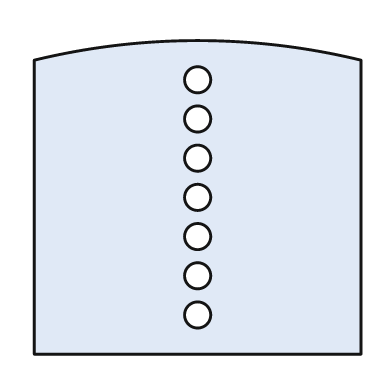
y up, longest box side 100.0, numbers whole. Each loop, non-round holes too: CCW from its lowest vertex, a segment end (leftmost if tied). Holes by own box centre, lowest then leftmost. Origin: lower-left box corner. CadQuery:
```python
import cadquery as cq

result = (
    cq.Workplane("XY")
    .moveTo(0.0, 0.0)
    .lineTo(100.0, 0.0)
    .lineTo(100.0, 90.0)
    .threePointArc((50.0, 96.0), (0.0, 90.0))
    .close()
    .moveTo(50.0, 12.0)
    .circle(4.0)
    .moveTo(50.0, 24.0)
    .circle(4.0)
    .moveTo(50.0, 36.0)
    .circle(4.0)
    .moveTo(50.0, 48.0)
    .circle(4.0)
    .moveTo(50.0, 60.0)
    .circle(4.0)
    .moveTo(50.0, 72.0)
    .circle(4.0)
    .moveTo(50.0, 84.0)
    .circle(4.0)
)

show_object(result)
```